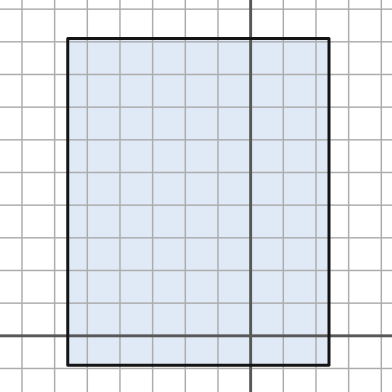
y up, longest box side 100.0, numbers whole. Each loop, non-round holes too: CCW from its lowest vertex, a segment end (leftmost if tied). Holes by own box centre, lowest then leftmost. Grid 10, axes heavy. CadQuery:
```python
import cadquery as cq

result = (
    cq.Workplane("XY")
    .moveTo(-56.0, -9.0)
    .lineTo(24.0, -9.0)
    .lineTo(24.0, 91.0)
    .lineTo(-56.0, 91.0)
    .close()
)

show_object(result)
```